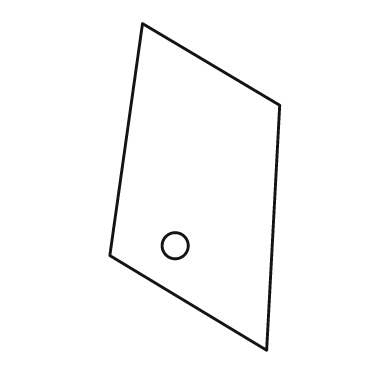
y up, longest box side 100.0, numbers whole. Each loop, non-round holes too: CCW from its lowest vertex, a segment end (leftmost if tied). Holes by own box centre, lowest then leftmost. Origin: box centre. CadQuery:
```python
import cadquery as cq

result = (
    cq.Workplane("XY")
    .moveTo(22.0, -50.0)
    .lineTo(26.0, 25.0)
    .lineTo(-16.0, 50.0)
    .lineTo(-26.0, -21.0)
    .close()
    .moveTo(-6.0, -18.0)
    .circle(4.0)
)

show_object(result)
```